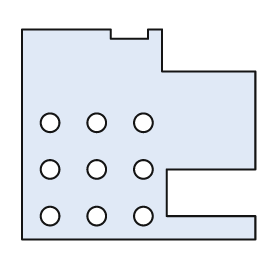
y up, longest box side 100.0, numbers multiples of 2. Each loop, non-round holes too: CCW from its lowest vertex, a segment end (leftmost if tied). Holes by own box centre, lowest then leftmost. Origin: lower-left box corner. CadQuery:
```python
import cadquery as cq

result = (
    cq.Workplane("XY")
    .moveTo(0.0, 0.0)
    .lineTo(100.0, 0.0)
    .lineTo(100.0, 10.0)
    .lineTo(62.0, 10.0)
    .lineTo(62.0, 30.0)
    .lineTo(100.0, 30.0)
    .lineTo(100.0, 72.0)
    .lineTo(60.0, 72.0)
    .lineTo(60.0, 90.0)
    .lineTo(54.0, 90.0)
    .lineTo(54.0, 86.0)
    .lineTo(38.0, 86.0)
    .lineTo(38.0, 90.0)
    .lineTo(0.0, 90.0)
    .close()
    .moveTo(12.0, 10.0)
    .circle(4.0)
    .moveTo(32.0, 10.0)
    .circle(4.0)
    .moveTo(52.0, 10.0)
    .circle(4.0)
    .moveTo(12.0, 30.0)
    .circle(4.0)
    .moveTo(32.0, 30.0)
    .circle(4.0)
    .moveTo(52.0, 30.0)
    .circle(4.0)
    .moveTo(12.0, 50.0)
    .circle(4.0)
    .moveTo(32.0, 50.0)
    .circle(4.0)
    .moveTo(52.0, 50.0)
    .circle(4.0)
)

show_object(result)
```